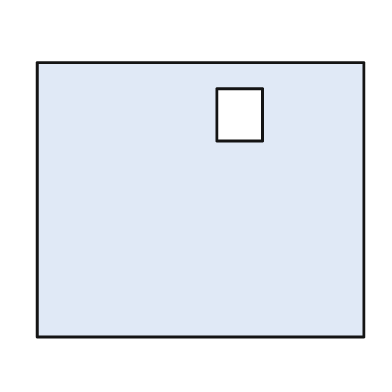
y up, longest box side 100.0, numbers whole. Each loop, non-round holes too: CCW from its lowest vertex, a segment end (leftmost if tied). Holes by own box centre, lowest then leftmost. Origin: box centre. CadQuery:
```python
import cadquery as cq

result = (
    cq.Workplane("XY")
    .moveTo(-50.0, -42.0)
    .lineTo(50.0, -42.0)
    .lineTo(50.0, 42.0)
    .lineTo(-50.0, 42.0)
    .close()
    .moveTo(5.0, 18.0)
    .lineTo(19.0, 18.0)
    .lineTo(19.0, 34.0)
    .lineTo(5.0, 34.0)
    .close()
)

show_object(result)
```